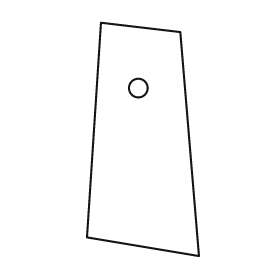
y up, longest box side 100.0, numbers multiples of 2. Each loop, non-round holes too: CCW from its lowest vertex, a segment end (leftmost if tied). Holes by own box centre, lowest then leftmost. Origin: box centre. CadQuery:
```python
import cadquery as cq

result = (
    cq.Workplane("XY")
    .moveTo(24.0, -50.0)
    .lineTo(16.0, 46.0)
    .lineTo(-18.0, 50.0)
    .lineTo(-24.0, -42.0)
    .close()
    .moveTo(-2.0, 22.0)
    .circle(4.0)
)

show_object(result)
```